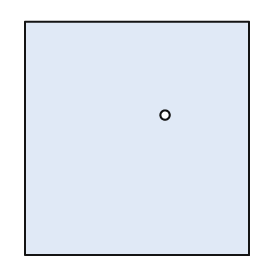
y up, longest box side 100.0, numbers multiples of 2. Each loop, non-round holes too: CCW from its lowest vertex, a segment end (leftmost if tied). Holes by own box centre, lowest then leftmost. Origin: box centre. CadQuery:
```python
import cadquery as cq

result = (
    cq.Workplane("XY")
    .moveTo(-48.0, -50.0)
    .lineTo(48.0, -50.0)
    .lineTo(48.0, 50.0)
    .lineTo(-48.0, 50.0)
    .close()
    .moveTo(12.0, 10.0)
    .circle(2.0)
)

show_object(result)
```